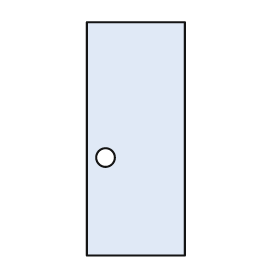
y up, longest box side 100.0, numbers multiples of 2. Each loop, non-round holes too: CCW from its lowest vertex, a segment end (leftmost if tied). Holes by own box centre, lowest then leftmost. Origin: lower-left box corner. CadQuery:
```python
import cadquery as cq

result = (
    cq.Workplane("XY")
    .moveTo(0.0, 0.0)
    .lineTo(42.0, 0.0)
    .lineTo(42.0, 100.0)
    .lineTo(0.0, 100.0)
    .close()
    .moveTo(8.0, 42.0)
    .circle(4.0)
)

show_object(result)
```